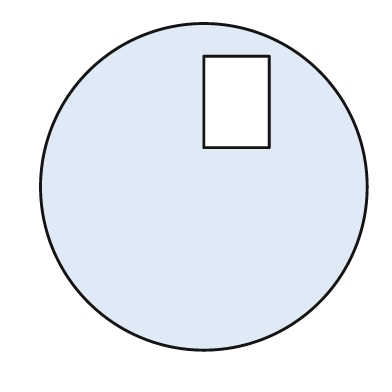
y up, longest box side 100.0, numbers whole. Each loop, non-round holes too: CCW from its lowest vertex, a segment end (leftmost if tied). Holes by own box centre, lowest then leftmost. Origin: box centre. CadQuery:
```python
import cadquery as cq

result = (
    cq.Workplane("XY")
    .moveTo(0.0, 0.0)
    .circle(50.0)
    .moveTo(0.0, 12.0)
    .lineTo(20.0, 12.0)
    .lineTo(20.0, 40.0)
    .lineTo(0.0, 40.0)
    .close()
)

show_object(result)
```